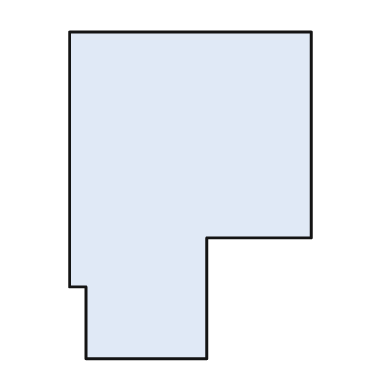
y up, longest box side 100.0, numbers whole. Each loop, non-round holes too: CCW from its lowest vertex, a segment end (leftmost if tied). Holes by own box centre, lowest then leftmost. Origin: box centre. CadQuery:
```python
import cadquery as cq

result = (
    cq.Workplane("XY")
    .moveTo(-32.0, -50.0)
    .lineTo(5.0, -50.0)
    .lineTo(5.0, -13.0)
    .lineTo(37.0, -13.0)
    .lineTo(37.0, 50.0)
    .lineTo(-37.0, 50.0)
    .lineTo(-37.0, -28.0)
    .lineTo(-32.0, -28.0)
    .close()
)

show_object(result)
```